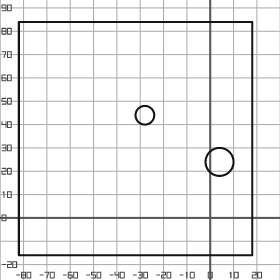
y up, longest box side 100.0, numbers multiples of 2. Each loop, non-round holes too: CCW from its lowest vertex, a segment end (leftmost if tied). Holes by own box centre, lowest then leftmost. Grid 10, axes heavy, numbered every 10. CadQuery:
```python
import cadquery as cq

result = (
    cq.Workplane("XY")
    .moveTo(-82.0, -16.0)
    .lineTo(18.0, -16.0)
    .lineTo(18.0, 84.0)
    .lineTo(-82.0, 84.0)
    .close()
    .moveTo(4.0, 24.0)
    .circle(6.0)
    .moveTo(-28.0, 44.0)
    .circle(4.0)
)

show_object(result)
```